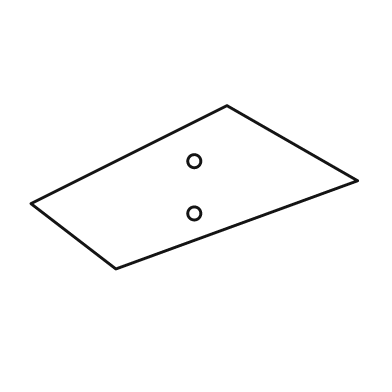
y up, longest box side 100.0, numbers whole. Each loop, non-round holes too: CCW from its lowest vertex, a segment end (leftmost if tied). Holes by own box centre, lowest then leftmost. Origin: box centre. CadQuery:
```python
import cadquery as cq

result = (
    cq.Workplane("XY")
    .moveTo(-24.0, -25.0)
    .lineTo(50.0, 2.0)
    .lineTo(10.0, 25.0)
    .lineTo(-50.0, -5.0)
    .close()
    .moveTo(0.0, -8.0)
    .circle(2.0)
    .moveTo(0.0, 8.0)
    .circle(2.0)
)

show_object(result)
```